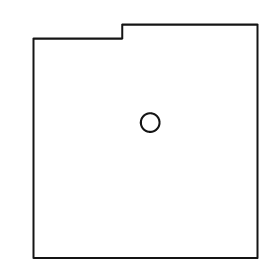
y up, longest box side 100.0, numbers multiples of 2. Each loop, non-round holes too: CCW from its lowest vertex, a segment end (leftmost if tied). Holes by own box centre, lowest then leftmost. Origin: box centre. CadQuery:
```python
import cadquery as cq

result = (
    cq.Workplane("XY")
    .moveTo(-48.0, -50.0)
    .lineTo(48.0, -50.0)
    .lineTo(48.0, 50.0)
    .lineTo(-10.0, 50.0)
    .lineTo(-10.0, 44.0)
    .lineTo(-48.0, 44.0)
    .close()
    .moveTo(2.0, 8.0)
    .circle(4.0)
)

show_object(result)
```